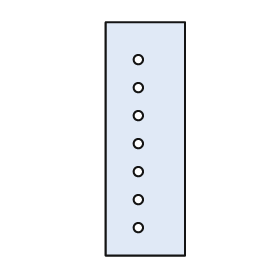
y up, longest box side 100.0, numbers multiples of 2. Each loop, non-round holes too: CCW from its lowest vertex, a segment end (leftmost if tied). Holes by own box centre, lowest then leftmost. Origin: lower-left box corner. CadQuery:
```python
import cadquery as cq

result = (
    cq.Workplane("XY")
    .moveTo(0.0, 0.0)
    .lineTo(34.0, 0.0)
    .lineTo(34.0, 100.0)
    .lineTo(0.0, 100.0)
    .close()
    .moveTo(14.0, 12.0)
    .circle(2.0)
    .moveTo(14.0, 24.0)
    .circle(2.0)
    .moveTo(14.0, 36.0)
    .circle(2.0)
    .moveTo(14.0, 48.0)
    .circle(2.0)
    .moveTo(14.0, 60.0)
    .circle(2.0)
    .moveTo(14.0, 72.0)
    .circle(2.0)
    .moveTo(14.0, 84.0)
    .circle(2.0)
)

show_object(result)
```